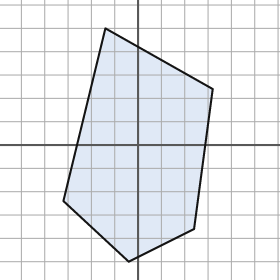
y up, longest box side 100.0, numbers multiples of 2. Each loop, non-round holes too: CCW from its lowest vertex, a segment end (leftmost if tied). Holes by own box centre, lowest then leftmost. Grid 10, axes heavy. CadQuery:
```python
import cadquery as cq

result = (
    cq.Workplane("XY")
    .moveTo(-4.0, -50.0)
    .lineTo(24.0, -36.0)
    .lineTo(32.0, 24.0)
    .lineTo(-14.0, 50.0)
    .lineTo(-32.0, -24.0)
    .close()
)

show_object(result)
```